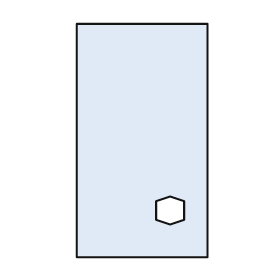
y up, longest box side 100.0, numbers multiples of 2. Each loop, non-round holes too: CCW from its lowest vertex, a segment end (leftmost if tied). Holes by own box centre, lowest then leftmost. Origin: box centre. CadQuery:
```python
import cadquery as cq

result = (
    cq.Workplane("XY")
    .moveTo(-28.0, -50.0)
    .lineTo(28.0, -50.0)
    .lineTo(28.0, 50.0)
    .lineTo(-28.0, 50.0)
    .close()
    .moveTo(12.0, -36.0)
    .lineTo(18.0, -34.0)
    .lineTo(18.0, -26.0)
    .lineTo(12.0, -24.0)
    .lineTo(6.0, -26.0)
    .lineTo(6.0, -34.0)
    .close()
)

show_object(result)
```